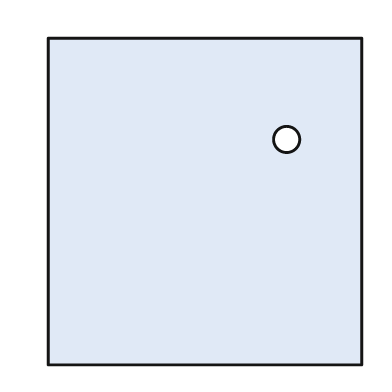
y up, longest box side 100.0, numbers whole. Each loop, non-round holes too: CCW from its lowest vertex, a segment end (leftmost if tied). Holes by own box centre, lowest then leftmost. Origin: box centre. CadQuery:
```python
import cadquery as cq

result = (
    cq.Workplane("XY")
    .moveTo(-48.0, -50.0)
    .lineTo(48.0, -50.0)
    .lineTo(48.0, 50.0)
    .lineTo(-48.0, 50.0)
    .close()
    .moveTo(25.0, 19.0)
    .circle(4.0)
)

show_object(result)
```